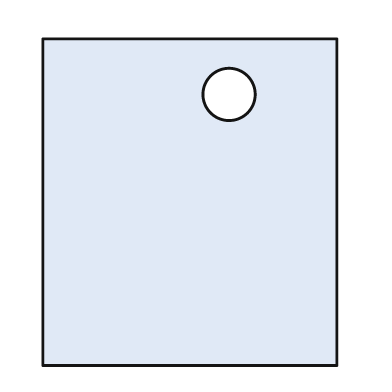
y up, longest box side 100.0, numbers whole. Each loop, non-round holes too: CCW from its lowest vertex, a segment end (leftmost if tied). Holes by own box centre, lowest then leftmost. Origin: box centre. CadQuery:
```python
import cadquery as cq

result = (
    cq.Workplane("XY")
    .moveTo(-45.0, -50.0)
    .lineTo(45.0, -50.0)
    .lineTo(45.0, 50.0)
    .lineTo(-45.0, 50.0)
    .close()
    .moveTo(12.0, 33.0)
    .circle(8.0)
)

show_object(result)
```